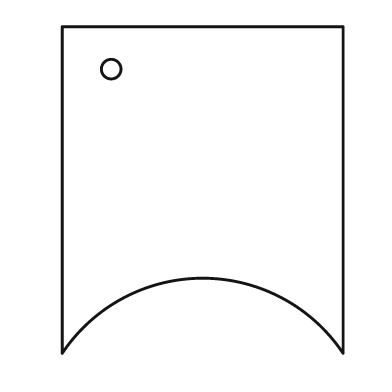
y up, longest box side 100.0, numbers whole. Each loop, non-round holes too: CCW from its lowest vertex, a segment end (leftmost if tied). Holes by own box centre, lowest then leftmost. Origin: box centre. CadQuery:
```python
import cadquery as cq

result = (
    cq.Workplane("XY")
    .moveTo(-43.0, -50.0)
    .threePointArc((0.0, -27.0), (43.0, -50.0))
    .lineTo(43.0, 50.0)
    .lineTo(-43.0, 50.0)
    .close()
    .moveTo(-28.0, 37.0)
    .circle(3.0)
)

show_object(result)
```